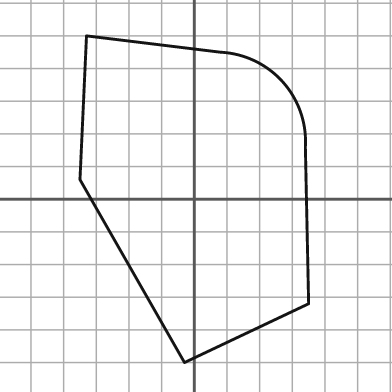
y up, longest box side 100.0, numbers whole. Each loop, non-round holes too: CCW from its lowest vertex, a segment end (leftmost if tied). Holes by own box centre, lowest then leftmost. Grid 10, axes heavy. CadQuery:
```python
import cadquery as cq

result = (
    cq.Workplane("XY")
    .moveTo(-3.0, -50.0)
    .lineTo(35.0, -32.0)
    .lineTo(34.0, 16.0)
    .threePointArc((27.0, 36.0), (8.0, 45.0))
    .lineTo(-33.0, 50.0)
    .lineTo(-35.0, 6.0)
    .close()
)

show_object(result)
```